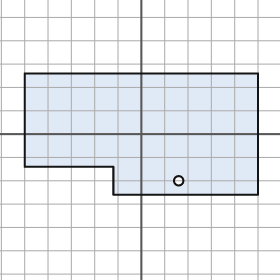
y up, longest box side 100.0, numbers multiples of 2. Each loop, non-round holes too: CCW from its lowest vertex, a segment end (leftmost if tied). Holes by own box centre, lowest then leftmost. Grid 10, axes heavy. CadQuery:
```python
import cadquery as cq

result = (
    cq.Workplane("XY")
    .moveTo(-12.0, -26.0)
    .lineTo(50.0, -26.0)
    .lineTo(50.0, 26.0)
    .lineTo(-50.0, 26.0)
    .lineTo(-50.0, -14.0)
    .lineTo(-12.0, -14.0)
    .close()
    .moveTo(16.0, -20.0)
    .circle(2.0)
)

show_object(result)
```